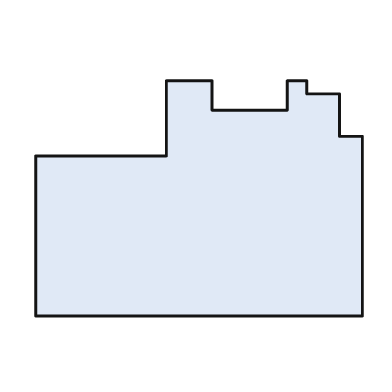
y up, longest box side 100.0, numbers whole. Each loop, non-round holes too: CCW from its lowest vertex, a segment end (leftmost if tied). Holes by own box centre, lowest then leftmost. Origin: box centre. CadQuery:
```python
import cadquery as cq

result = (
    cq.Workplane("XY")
    .moveTo(-50.0, -36.0)
    .lineTo(50.0, -36.0)
    .lineTo(50.0, 19.0)
    .lineTo(43.0, 19.0)
    .lineTo(43.0, 32.0)
    .lineTo(33.0, 32.0)
    .lineTo(33.0, 36.0)
    .lineTo(27.0, 36.0)
    .lineTo(27.0, 27.0)
    .lineTo(4.0, 27.0)
    .lineTo(4.0, 36.0)
    .lineTo(-10.0, 36.0)
    .lineTo(-10.0, 13.0)
    .lineTo(-50.0, 13.0)
    .close()
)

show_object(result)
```